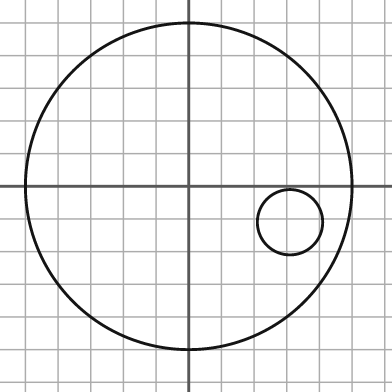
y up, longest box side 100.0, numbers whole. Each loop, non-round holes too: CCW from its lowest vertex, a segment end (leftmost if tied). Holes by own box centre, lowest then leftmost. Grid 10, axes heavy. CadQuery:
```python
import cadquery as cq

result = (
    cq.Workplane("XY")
    .moveTo(0.0, 0.0)
    .circle(50.0)
    .moveTo(31.0, -11.0)
    .circle(10.0)
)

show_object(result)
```